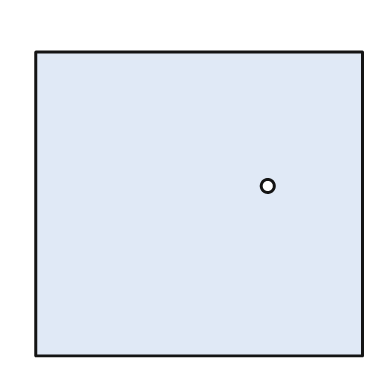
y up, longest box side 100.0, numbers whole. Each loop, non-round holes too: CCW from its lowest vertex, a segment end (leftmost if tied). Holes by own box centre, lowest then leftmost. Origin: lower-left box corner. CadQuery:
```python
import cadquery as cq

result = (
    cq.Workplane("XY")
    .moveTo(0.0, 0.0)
    .lineTo(100.0, 0.0)
    .lineTo(100.0, 93.0)
    .lineTo(0.0, 93.0)
    .close()
    .moveTo(71.0, 52.0)
    .circle(2.0)
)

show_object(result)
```